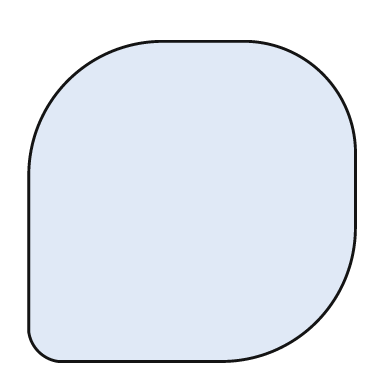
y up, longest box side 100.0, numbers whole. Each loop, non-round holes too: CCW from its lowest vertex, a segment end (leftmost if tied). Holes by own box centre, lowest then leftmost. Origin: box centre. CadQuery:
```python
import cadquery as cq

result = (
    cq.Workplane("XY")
    .moveTo(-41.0, -49.0)
    .lineTo(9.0, -49.0)
    .threePointArc((38.0, -37.0), (50.0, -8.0))
    .lineTo(50.0, 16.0)
    .threePointArc((40.0, 39.0), (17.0, 49.0))
    .lineTo(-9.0, 49.0)
    .threePointArc((-38.0, 37.0), (-50.0, 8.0))
    .lineTo(-50.0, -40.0)
    .threePointArc((-47.0, -46.0), (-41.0, -49.0))
    .close()
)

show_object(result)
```